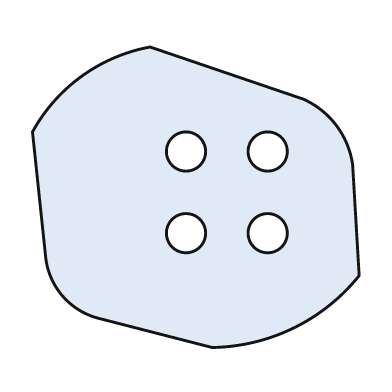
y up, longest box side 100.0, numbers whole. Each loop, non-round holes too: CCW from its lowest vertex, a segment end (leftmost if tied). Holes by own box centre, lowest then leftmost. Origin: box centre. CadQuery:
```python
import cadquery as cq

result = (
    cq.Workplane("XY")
    .moveTo(5.0, -46.0)
    .threePointArc((30.0, -40.0), (50.0, -24.0))
    .lineTo(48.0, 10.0)
    .threePointArc((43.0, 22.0), (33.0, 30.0))
    .lineTo(-14.0, 46.0)
    .threePointArc((-35.0, 37.0), (-50.0, 20.0))
    .lineTo(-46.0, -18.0)
    .threePointArc((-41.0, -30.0), (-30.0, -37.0))
    .close()
    .moveTo(-3.0, -11.0)
    .circle(6.0)
    .moveTo(22.0, -11.0)
    .circle(6.0)
    .moveTo(-3.0, 14.0)
    .circle(6.0)
    .moveTo(22.0, 14.0)
    .circle(6.0)
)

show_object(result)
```